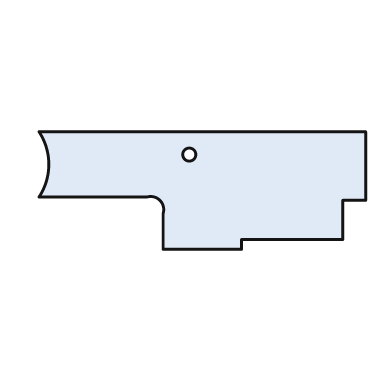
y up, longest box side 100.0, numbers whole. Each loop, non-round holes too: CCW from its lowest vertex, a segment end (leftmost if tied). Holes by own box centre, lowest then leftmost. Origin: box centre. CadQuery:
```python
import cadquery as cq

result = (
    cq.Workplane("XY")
    .moveTo(-12.0, -18.0)
    .lineTo(12.0, -18.0)
    .lineTo(12.0, -15.0)
    .lineTo(43.0, -15.0)
    .lineTo(43.0, -3.0)
    .lineTo(50.0, -3.0)
    .lineTo(50.0, 18.0)
    .lineTo(-50.0, 18.0)
    .threePointArc((-47.0, 8.0), (-50.0, -2.0))
    .lineTo(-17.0, -2.0)
    .threePointArc((-13.0, -3.0), (-12.0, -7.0))
    .close()
    .moveTo(-4.0, 11.0)
    .circle(2.0)
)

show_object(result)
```